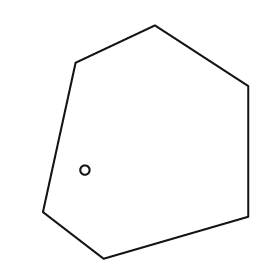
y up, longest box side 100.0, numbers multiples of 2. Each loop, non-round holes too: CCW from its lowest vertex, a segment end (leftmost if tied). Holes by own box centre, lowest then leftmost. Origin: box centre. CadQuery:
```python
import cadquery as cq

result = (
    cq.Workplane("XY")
    .moveTo(-18.0, -50.0)
    .lineTo(44.0, -32.0)
    .lineTo(44.0, 24.0)
    .lineTo(4.0, 50.0)
    .lineTo(-30.0, 34.0)
    .lineTo(-44.0, -30.0)
    .close()
    .moveTo(-26.0, -12.0)
    .circle(2.0)
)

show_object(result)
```